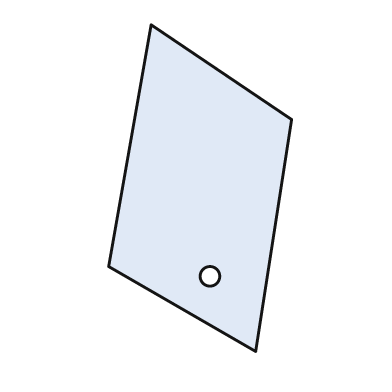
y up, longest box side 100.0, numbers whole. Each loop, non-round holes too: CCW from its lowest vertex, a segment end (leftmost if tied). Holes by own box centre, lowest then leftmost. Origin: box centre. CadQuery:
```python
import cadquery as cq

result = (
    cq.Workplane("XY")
    .moveTo(17.0, -50.0)
    .lineTo(28.0, 21.0)
    .lineTo(-15.0, 50.0)
    .lineTo(-28.0, -24.0)
    .close()
    .moveTo(3.0, -27.0)
    .circle(3.0)
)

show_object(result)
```